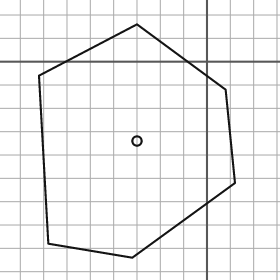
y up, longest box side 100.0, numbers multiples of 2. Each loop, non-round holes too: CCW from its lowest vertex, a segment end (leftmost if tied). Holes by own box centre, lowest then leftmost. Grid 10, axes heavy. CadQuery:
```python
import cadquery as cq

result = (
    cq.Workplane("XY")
    .moveTo(-32.0, -84.0)
    .lineTo(12.0, -52.0)
    .lineTo(8.0, -12.0)
    .lineTo(-30.0, 16.0)
    .lineTo(-72.0, -6.0)
    .lineTo(-68.0, -78.0)
    .close()
    .moveTo(-30.0, -34.0)
    .circle(2.0)
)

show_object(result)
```